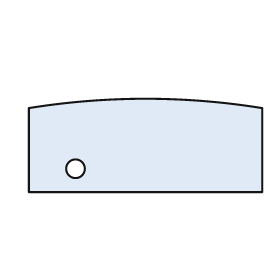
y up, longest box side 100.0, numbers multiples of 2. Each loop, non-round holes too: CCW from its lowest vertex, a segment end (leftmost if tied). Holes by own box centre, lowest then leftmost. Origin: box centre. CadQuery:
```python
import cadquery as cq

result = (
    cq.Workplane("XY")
    .moveTo(-50.0, -20.0)
    .lineTo(50.0, -20.0)
    .lineTo(50.0, 16.0)
    .threePointArc((0.0, 20.0), (-50.0, 16.0))
    .close()
    .moveTo(-30.0, -10.0)
    .circle(4.0)
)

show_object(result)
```